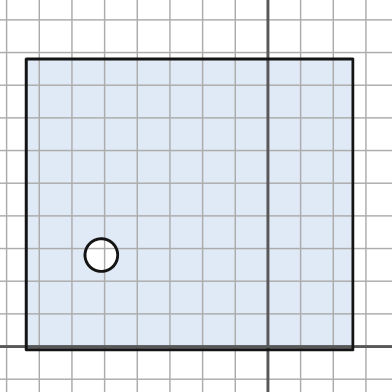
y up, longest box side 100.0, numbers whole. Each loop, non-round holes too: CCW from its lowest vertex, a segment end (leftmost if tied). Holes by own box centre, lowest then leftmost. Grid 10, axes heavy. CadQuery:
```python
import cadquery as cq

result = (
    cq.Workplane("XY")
    .moveTo(-74.0, -1.0)
    .lineTo(26.0, -1.0)
    .lineTo(26.0, 88.0)
    .lineTo(-74.0, 88.0)
    .close()
    .moveTo(-51.0, 28.0)
    .circle(5.0)
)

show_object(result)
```